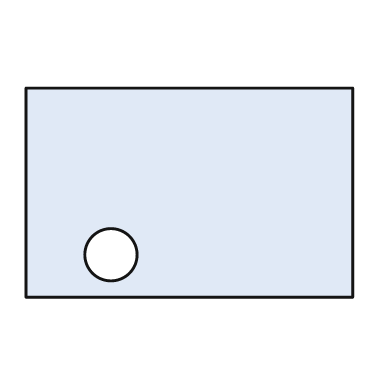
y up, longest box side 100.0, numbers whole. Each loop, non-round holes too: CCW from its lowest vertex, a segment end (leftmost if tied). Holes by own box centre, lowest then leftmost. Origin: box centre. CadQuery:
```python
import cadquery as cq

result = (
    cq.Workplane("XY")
    .moveTo(-50.0, -32.0)
    .lineTo(50.0, -32.0)
    .lineTo(50.0, 32.0)
    .lineTo(-50.0, 32.0)
    .close()
    .moveTo(-24.0, -19.0)
    .circle(8.0)
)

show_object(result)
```